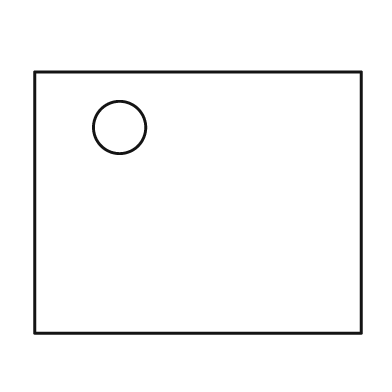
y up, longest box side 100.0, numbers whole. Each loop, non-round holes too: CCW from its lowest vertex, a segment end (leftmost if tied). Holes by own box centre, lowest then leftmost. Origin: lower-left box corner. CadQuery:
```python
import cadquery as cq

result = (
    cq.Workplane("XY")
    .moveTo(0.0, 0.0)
    .lineTo(100.0, 0.0)
    .lineTo(100.0, 80.0)
    .lineTo(0.0, 80.0)
    .close()
    .moveTo(26.0, 63.0)
    .circle(8.0)
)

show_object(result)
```